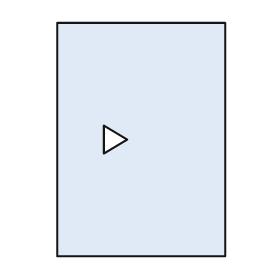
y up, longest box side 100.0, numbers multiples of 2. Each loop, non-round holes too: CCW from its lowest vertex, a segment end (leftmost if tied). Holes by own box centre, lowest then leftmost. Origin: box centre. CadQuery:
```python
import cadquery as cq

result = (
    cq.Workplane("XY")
    .moveTo(-36.0, -50.0)
    .lineTo(36.0, -50.0)
    .lineTo(36.0, 50.0)
    .lineTo(-36.0, 50.0)
    .close()
    .moveTo(-16.0, -6.0)
    .lineTo(-6.0, 0.0)
    .lineTo(-16.0, 6.0)
    .close()
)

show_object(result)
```